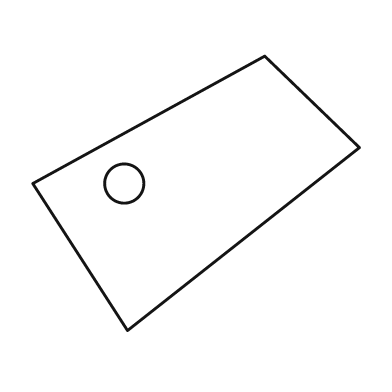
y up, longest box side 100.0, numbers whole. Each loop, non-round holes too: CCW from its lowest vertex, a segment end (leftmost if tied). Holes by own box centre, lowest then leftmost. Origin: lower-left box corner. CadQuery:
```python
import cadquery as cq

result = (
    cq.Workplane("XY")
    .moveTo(29.0, 0.0)
    .lineTo(100.0, 56.0)
    .lineTo(71.0, 84.0)
    .lineTo(0.0, 45.0)
    .close()
    .moveTo(28.0, 45.0)
    .circle(6.0)
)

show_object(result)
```